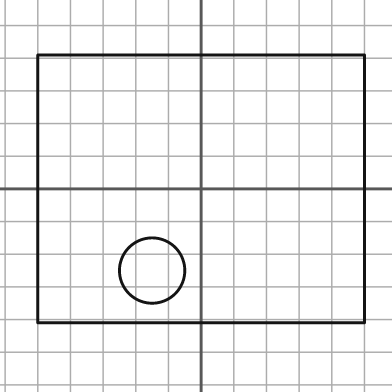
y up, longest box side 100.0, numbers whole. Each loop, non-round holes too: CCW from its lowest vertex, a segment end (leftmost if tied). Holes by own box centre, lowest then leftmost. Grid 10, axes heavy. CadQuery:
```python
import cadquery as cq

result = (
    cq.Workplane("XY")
    .moveTo(-50.0, -41.0)
    .lineTo(50.0, -41.0)
    .lineTo(50.0, 41.0)
    .lineTo(-50.0, 41.0)
    .close()
    .moveTo(-15.0, -25.0)
    .circle(10.0)
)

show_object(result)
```